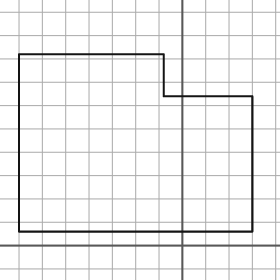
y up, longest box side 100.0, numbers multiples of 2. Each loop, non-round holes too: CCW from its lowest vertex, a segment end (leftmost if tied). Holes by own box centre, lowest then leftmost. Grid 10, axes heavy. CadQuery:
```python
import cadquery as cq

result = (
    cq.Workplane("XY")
    .moveTo(-70.0, 6.0)
    .lineTo(30.0, 6.0)
    .lineTo(30.0, 64.0)
    .lineTo(-8.0, 64.0)
    .lineTo(-8.0, 82.0)
    .lineTo(-70.0, 82.0)
    .close()
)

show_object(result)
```